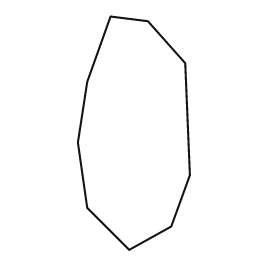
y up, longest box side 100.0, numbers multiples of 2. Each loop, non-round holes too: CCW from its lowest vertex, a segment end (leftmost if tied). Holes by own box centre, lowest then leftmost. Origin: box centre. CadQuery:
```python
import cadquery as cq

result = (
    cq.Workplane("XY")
    .moveTo(-2.0, -50.0)
    .lineTo(16.0, -40.0)
    .lineTo(24.0, -18.0)
    .lineTo(22.0, 30.0)
    .lineTo(6.0, 48.0)
    .lineTo(-10.0, 50.0)
    .lineTo(-20.0, 22.0)
    .lineTo(-24.0, -4.0)
    .lineTo(-20.0, -32.0)
    .close()
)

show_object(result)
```